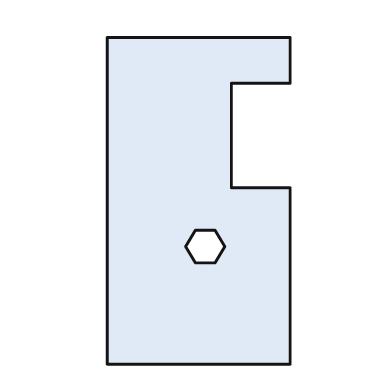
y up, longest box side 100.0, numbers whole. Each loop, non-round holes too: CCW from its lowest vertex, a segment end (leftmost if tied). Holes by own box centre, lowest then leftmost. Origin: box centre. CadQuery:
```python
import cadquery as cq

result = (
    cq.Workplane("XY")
    .moveTo(-28.0, -50.0)
    .lineTo(28.0, -50.0)
    .lineTo(28.0, 4.0)
    .lineTo(10.0, 4.0)
    .lineTo(10.0, 36.0)
    .lineTo(28.0, 36.0)
    .lineTo(28.0, 50.0)
    .lineTo(-28.0, 50.0)
    .close()
    .moveTo(-1.0, -19.0)
    .lineTo(5.0, -19.0)
    .lineTo(8.0, -14.0)
    .lineTo(5.0, -9.0)
    .lineTo(-1.0, -9.0)
    .lineTo(-4.0, -14.0)
    .close()
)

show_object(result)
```